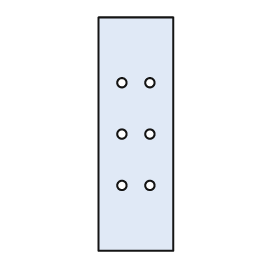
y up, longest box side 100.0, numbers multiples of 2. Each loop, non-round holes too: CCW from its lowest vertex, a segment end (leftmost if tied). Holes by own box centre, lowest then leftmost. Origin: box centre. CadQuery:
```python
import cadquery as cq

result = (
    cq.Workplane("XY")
    .moveTo(-16.0, -50.0)
    .lineTo(16.0, -50.0)
    .lineTo(16.0, 50.0)
    .lineTo(-16.0, 50.0)
    .close()
    .moveTo(-6.0, -22.0)
    .circle(2.0)
    .moveTo(6.0, -22.0)
    .circle(2.0)
    .moveTo(-6.0, 0.0)
    .circle(2.0)
    .moveTo(6.0, 0.0)
    .circle(2.0)
    .moveTo(-6.0, 22.0)
    .circle(2.0)
    .moveTo(6.0, 22.0)
    .circle(2.0)
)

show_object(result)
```